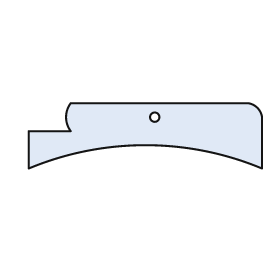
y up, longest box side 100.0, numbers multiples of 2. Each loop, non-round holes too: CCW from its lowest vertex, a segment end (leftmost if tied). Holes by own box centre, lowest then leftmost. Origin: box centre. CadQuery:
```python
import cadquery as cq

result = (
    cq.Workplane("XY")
    .moveTo(-50.0, -14.0)
    .threePointArc((0.0, -4.0), (50.0, -14.0))
    .lineTo(50.0, 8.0)
    .threePointArc((48.0, 12.0), (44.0, 14.0))
    .lineTo(-32.0, 14.0)
    .threePointArc((-34.0, 8.0), (-32.0, 2.0))
    .lineTo(-50.0, 2.0)
    .close()
    .moveTo(4.0, 8.0)
    .circle(2.0)
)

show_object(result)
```